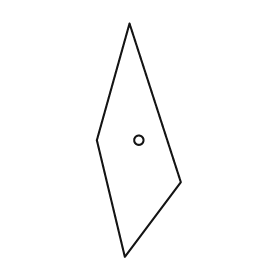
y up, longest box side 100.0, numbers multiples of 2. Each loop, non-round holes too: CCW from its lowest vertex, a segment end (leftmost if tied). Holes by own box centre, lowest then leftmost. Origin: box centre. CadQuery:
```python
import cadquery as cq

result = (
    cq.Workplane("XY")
    .moveTo(-6.0, -50.0)
    .lineTo(18.0, -18.0)
    .lineTo(-4.0, 50.0)
    .lineTo(-18.0, 0.0)
    .close()
    .moveTo(0.0, 0.0)
    .circle(2.0)
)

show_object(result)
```